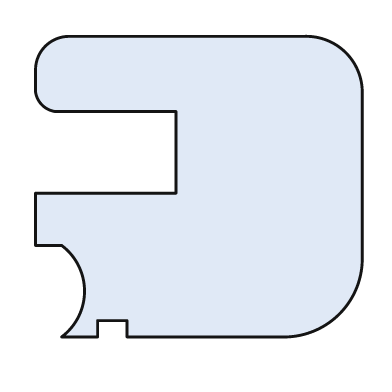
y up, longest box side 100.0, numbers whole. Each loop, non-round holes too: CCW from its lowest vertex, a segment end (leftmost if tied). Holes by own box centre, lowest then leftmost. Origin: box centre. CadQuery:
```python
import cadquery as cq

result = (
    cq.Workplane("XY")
    .moveTo(-42.0, -46.0)
    .lineTo(-31.0, -46.0)
    .lineTo(-31.0, -41.0)
    .lineTo(-22.0, -41.0)
    .lineTo(-22.0, -46.0)
    .lineTo(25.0, -46.0)
    .threePointArc((43.0, -39.0), (50.0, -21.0))
    .lineTo(50.0, 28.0)
    .threePointArc((45.0, 41.0), (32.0, 46.0))
    .lineTo(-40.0, 46.0)
    .threePointArc((-47.0, 43.0), (-50.0, 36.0))
    .lineTo(-50.0, 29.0)
    .threePointArc((-48.0, 25.0), (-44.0, 23.0))
    .lineTo(-7.0, 23.0)
    .lineTo(-7.0, -2.0)
    .lineTo(-50.0, -2.0)
    .lineTo(-50.0, -18.0)
    .lineTo(-42.0, -18.0)
    .threePointArc((-35.0, -32.0), (-42.0, -46.0))
    .close()
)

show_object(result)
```